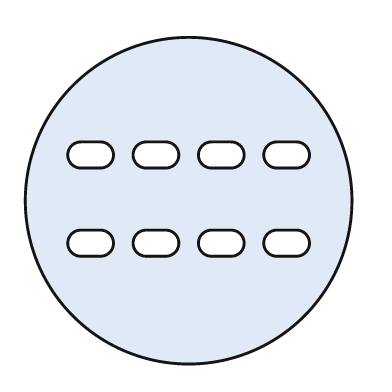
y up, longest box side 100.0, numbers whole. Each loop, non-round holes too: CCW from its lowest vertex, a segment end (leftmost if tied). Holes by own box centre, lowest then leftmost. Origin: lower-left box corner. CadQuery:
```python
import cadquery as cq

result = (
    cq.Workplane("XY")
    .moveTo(50.0, 50.0)
    .circle(50.0)
    .moveTo(17.0, 33.0)
    .lineTo(23.0, 33.0)
    .threePointArc((27.0, 37.0), (23.0, 41.0))
    .lineTo(17.0, 41.0)
    .threePointArc((13.0, 37.0), (17.0, 33.0))
    .close()
    .moveTo(37.0, 33.0)
    .lineTo(43.0, 33.0)
    .threePointArc((47.0, 37.0), (43.0, 41.0))
    .lineTo(37.0, 41.0)
    .threePointArc((33.0, 37.0), (37.0, 33.0))
    .close()
    .moveTo(57.0, 33.0)
    .lineTo(63.0, 33.0)
    .threePointArc((67.0, 37.0), (63.0, 41.0))
    .lineTo(57.0, 41.0)
    .threePointArc((53.0, 37.0), (57.0, 33.0))
    .close()
    .moveTo(77.0, 33.0)
    .lineTo(83.0, 33.0)
    .threePointArc((87.0, 37.0), (83.0, 41.0))
    .lineTo(77.0, 41.0)
    .threePointArc((73.0, 37.0), (77.0, 33.0))
    .close()
    .moveTo(17.0, 60.0)
    .lineTo(23.0, 60.0)
    .threePointArc((27.0, 64.0), (23.0, 68.0))
    .lineTo(17.0, 68.0)
    .threePointArc((13.0, 64.0), (17.0, 60.0))
    .close()
    .moveTo(37.0, 60.0)
    .lineTo(43.0, 60.0)
    .threePointArc((47.0, 64.0), (43.0, 68.0))
    .lineTo(37.0, 68.0)
    .threePointArc((33.0, 64.0), (37.0, 60.0))
    .close()
    .moveTo(57.0, 60.0)
    .lineTo(63.0, 60.0)
    .threePointArc((67.0, 64.0), (63.0, 68.0))
    .lineTo(57.0, 68.0)
    .threePointArc((53.0, 64.0), (57.0, 60.0))
    .close()
    .moveTo(77.0, 60.0)
    .lineTo(83.0, 60.0)
    .threePointArc((87.0, 64.0), (83.0, 68.0))
    .lineTo(77.0, 68.0)
    .threePointArc((73.0, 64.0), (77.0, 60.0))
    .close()
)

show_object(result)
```